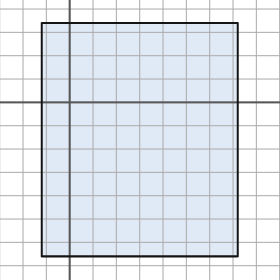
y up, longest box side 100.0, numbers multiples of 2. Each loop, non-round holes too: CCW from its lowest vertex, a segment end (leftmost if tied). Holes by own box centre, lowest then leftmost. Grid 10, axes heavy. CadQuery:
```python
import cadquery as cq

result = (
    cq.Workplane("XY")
    .moveTo(-12.0, -66.0)
    .lineTo(72.0, -66.0)
    .lineTo(72.0, 34.0)
    .lineTo(-12.0, 34.0)
    .close()
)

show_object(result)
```